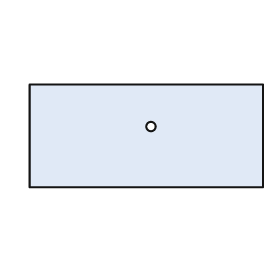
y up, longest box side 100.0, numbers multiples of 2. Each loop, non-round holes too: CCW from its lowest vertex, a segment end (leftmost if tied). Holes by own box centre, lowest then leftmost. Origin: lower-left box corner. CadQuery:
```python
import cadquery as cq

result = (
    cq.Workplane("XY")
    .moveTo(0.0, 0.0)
    .lineTo(100.0, 0.0)
    .lineTo(100.0, 44.0)
    .lineTo(0.0, 44.0)
    .close()
    .moveTo(52.0, 26.0)
    .circle(2.0)
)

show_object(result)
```